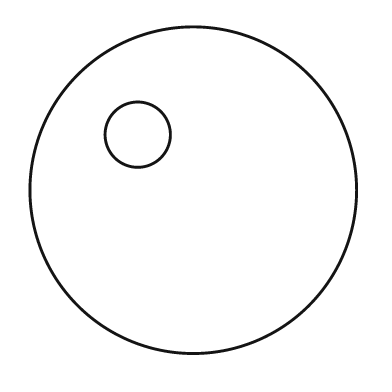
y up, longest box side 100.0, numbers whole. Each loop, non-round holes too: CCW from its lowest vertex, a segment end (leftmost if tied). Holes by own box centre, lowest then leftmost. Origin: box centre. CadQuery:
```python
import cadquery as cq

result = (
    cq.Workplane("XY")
    .moveTo(0.0, 0.0)
    .circle(50.0)
    .moveTo(-17.0, 17.0)
    .circle(10.0)
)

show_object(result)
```